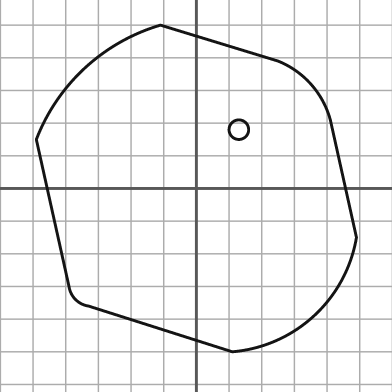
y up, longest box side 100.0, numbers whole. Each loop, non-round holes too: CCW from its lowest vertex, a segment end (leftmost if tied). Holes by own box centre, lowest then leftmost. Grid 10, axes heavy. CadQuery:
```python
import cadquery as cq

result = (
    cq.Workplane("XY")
    .moveTo(11.0, -50.0)
    .threePointArc((36.0, -39.0), (49.0, -15.0))
    .lineTo(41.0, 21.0)
    .threePointArc((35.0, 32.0), (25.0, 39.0))
    .lineTo(-11.0, 50.0)
    .threePointArc((-34.0, 37.0), (-49.0, 15.0))
    .lineTo(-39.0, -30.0)
    .threePointArc((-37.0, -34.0), (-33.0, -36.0))
    .close()
    .moveTo(13.0, 18.0)
    .circle(3.0)
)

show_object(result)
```